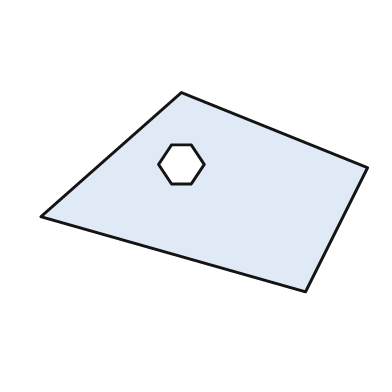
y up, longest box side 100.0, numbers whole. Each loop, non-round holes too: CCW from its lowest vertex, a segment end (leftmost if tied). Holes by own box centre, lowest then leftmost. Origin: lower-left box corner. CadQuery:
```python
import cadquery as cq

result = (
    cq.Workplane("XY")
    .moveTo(81.0, 0.0)
    .lineTo(100.0, 38.0)
    .lineTo(43.0, 61.0)
    .lineTo(0.0, 23.0)
    .close()
    .moveTo(40.0, 33.0)
    .lineTo(46.0, 33.0)
    .lineTo(50.0, 39.0)
    .lineTo(46.0, 45.0)
    .lineTo(40.0, 45.0)
    .lineTo(36.0, 39.0)
    .close()
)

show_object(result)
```